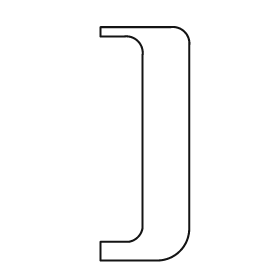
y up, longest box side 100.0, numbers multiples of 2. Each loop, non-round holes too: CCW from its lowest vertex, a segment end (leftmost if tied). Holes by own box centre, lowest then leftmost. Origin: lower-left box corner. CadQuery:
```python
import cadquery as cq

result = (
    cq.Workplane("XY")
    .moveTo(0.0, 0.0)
    .lineTo(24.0, 0.0)
    .threePointArc((34.0, 4.0), (38.0, 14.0))
    .lineTo(38.0, 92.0)
    .threePointArc((36.0, 98.0), (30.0, 100.0))
    .lineTo(0.0, 100.0)
    .lineTo(0.0, 96.0)
    .lineTo(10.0, 96.0)
    .threePointArc((16.0, 94.0), (18.0, 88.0))
    .lineTo(18.0, 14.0)
    .threePointArc((16.0, 10.0), (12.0, 8.0))
    .lineTo(0.0, 8.0)
    .close()
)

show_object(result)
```